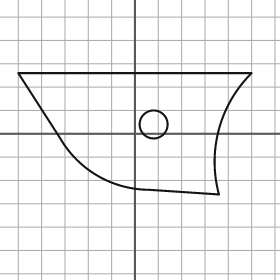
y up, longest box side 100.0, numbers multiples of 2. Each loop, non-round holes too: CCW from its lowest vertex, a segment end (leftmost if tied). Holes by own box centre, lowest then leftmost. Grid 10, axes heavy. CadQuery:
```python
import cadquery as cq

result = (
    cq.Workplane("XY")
    .moveTo(36.0, -26.0)
    .threePointArc((36.0, 2.0), (50.0, 26.0))
    .lineTo(-50.0, 26.0)
    .lineTo(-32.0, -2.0)
    .threePointArc((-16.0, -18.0), (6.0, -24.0))
    .close()
    .moveTo(8.0, 4.0)
    .circle(6.0)
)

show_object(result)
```